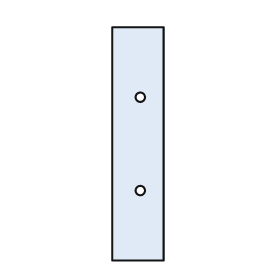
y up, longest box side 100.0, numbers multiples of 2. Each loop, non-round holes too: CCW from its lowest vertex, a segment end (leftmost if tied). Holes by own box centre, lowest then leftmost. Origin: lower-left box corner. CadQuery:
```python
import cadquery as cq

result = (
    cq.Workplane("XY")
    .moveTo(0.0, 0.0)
    .lineTo(22.0, 0.0)
    .lineTo(22.0, 100.0)
    .lineTo(0.0, 100.0)
    .close()
    .moveTo(12.0, 30.0)
    .circle(2.0)
    .moveTo(12.0, 70.0)
    .circle(2.0)
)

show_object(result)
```